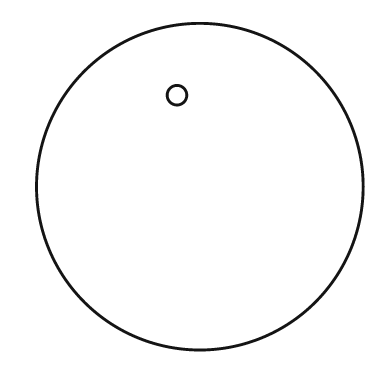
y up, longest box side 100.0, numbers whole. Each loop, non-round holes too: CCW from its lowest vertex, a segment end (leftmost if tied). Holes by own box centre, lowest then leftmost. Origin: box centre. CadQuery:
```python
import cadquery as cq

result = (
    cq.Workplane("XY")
    .moveTo(0.0, 0.0)
    .circle(50.0)
    .moveTo(-7.0, 28.0)
    .circle(3.0)
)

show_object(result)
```